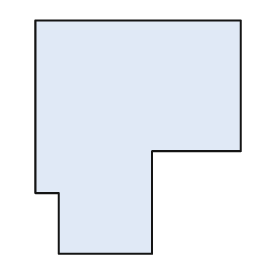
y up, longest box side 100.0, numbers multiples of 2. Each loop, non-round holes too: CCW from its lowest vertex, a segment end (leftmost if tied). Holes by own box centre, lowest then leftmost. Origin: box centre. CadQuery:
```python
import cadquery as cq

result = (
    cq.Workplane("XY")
    .moveTo(-34.0, -50.0)
    .lineTo(6.0, -50.0)
    .lineTo(6.0, -6.0)
    .lineTo(44.0, -6.0)
    .lineTo(44.0, 50.0)
    .lineTo(-44.0, 50.0)
    .lineTo(-44.0, -24.0)
    .lineTo(-34.0, -24.0)
    .close()
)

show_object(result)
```